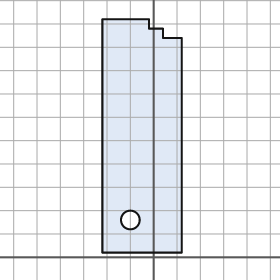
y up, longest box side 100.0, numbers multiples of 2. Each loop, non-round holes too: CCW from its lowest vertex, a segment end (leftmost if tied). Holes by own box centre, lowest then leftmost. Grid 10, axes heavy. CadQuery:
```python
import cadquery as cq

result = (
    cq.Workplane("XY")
    .moveTo(-22.0, 2.0)
    .lineTo(12.0, 2.0)
    .lineTo(12.0, 94.0)
    .lineTo(4.0, 94.0)
    .lineTo(4.0, 98.0)
    .lineTo(-2.0, 98.0)
    .lineTo(-2.0, 102.0)
    .lineTo(-22.0, 102.0)
    .close()
    .moveTo(-10.0, 16.0)
    .circle(4.0)
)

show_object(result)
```